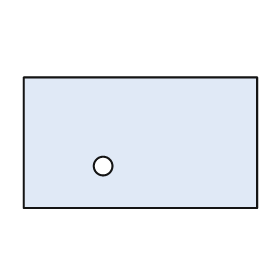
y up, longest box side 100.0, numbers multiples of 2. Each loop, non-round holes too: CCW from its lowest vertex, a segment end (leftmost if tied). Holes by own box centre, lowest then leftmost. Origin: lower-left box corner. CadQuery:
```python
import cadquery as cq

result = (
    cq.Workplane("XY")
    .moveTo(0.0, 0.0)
    .lineTo(100.0, 0.0)
    .lineTo(100.0, 56.0)
    .lineTo(0.0, 56.0)
    .close()
    .moveTo(34.0, 18.0)
    .circle(4.0)
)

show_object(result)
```